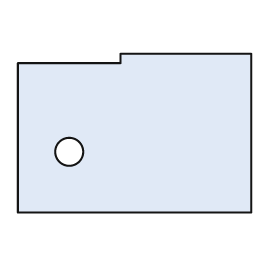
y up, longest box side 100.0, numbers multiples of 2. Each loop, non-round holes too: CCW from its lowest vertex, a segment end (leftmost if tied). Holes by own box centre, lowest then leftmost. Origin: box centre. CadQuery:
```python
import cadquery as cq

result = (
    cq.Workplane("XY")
    .moveTo(-50.0, -34.0)
    .lineTo(50.0, -34.0)
    .lineTo(50.0, 34.0)
    .lineTo(-6.0, 34.0)
    .lineTo(-6.0, 30.0)
    .lineTo(-50.0, 30.0)
    .close()
    .moveTo(-28.0, -8.0)
    .circle(6.0)
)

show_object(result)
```